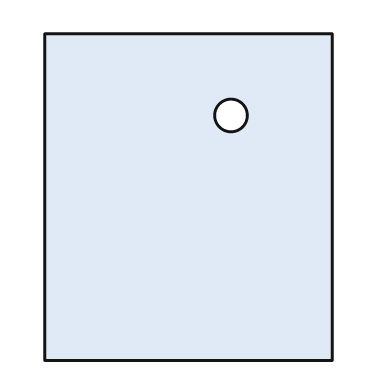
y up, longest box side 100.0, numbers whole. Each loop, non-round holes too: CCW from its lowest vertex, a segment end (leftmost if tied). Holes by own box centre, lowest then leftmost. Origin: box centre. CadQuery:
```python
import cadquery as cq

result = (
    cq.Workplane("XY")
    .moveTo(-44.0, -50.0)
    .lineTo(44.0, -50.0)
    .lineTo(44.0, 50.0)
    .lineTo(-44.0, 50.0)
    .close()
    .moveTo(13.0, 25.0)
    .circle(5.0)
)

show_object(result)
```